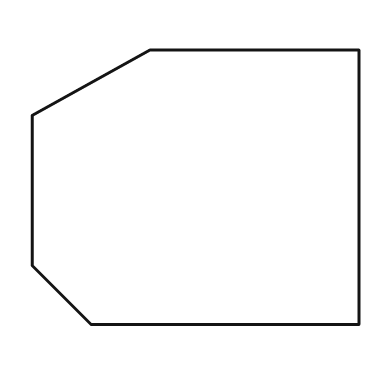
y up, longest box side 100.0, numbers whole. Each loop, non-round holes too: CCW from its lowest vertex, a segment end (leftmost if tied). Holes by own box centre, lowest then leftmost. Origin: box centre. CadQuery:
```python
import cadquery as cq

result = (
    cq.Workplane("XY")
    .moveTo(-32.0, -42.0)
    .lineTo(50.0, -42.0)
    .lineTo(50.0, 42.0)
    .lineTo(-14.0, 42.0)
    .lineTo(-50.0, 22.0)
    .lineTo(-50.0, -24.0)
    .close()
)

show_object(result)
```